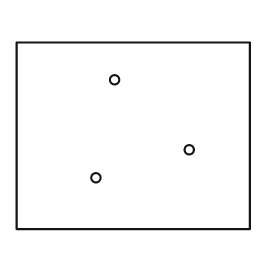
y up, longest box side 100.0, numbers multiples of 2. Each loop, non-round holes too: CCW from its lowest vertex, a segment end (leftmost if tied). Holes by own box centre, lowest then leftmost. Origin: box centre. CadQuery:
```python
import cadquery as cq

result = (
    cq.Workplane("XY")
    .moveTo(-50.0, -40.0)
    .lineTo(50.0, -40.0)
    .lineTo(50.0, 40.0)
    .lineTo(-50.0, 40.0)
    .close()
    .moveTo(-16.0, -18.0)
    .circle(2.0)
    .moveTo(24.0, -6.0)
    .circle(2.0)
    .moveTo(-8.0, 24.0)
    .circle(2.0)
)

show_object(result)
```